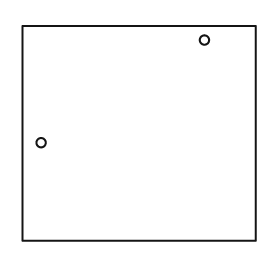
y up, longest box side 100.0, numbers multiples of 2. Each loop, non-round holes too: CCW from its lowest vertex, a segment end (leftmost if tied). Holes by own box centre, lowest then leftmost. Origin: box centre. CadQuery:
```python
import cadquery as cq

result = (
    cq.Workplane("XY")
    .moveTo(-50.0, -46.0)
    .lineTo(50.0, -46.0)
    .lineTo(50.0, 46.0)
    .lineTo(-50.0, 46.0)
    .close()
    .moveTo(-42.0, -4.0)
    .circle(2.0)
    .moveTo(28.0, 40.0)
    .circle(2.0)
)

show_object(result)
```